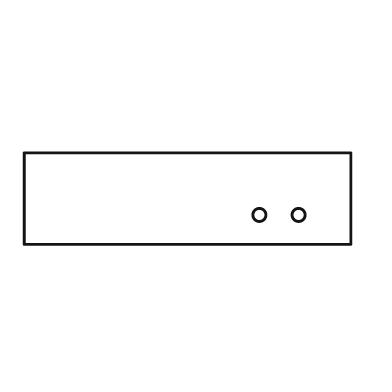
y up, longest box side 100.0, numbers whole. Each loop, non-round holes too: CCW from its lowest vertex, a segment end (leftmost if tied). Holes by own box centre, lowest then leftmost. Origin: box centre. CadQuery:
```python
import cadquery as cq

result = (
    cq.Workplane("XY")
    .moveTo(-50.0, -14.0)
    .lineTo(50.0, -14.0)
    .lineTo(50.0, 14.0)
    .lineTo(-50.0, 14.0)
    .close()
    .moveTo(22.0, -5.0)
    .circle(2.0)
    .moveTo(34.0, -5.0)
    .circle(2.0)
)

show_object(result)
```